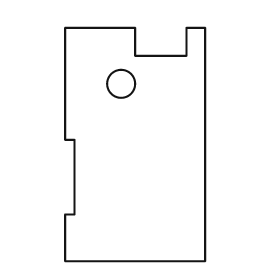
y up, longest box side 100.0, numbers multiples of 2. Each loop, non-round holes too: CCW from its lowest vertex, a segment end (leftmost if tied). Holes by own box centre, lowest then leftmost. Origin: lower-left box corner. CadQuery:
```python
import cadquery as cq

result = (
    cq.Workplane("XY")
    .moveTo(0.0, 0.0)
    .lineTo(60.0, 0.0)
    .lineTo(60.0, 100.0)
    .lineTo(52.0, 100.0)
    .lineTo(52.0, 88.0)
    .lineTo(30.0, 88.0)
    .lineTo(30.0, 100.0)
    .lineTo(0.0, 100.0)
    .lineTo(0.0, 52.0)
    .lineTo(4.0, 52.0)
    .lineTo(4.0, 20.0)
    .lineTo(0.0, 20.0)
    .close()
    .moveTo(24.0, 76.0)
    .circle(6.0)
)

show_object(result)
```